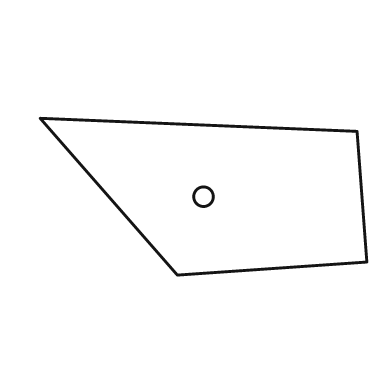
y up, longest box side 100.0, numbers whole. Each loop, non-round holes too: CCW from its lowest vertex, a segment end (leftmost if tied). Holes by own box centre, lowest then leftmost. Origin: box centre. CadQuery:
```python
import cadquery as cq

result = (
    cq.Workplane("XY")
    .moveTo(-8.0, -24.0)
    .lineTo(50.0, -20.0)
    .lineTo(47.0, 20.0)
    .lineTo(-50.0, 24.0)
    .close()
    .moveTo(0.0, 0.0)
    .circle(3.0)
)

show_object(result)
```